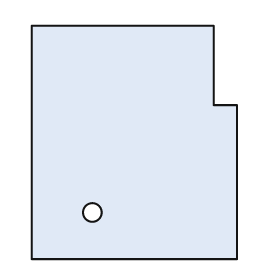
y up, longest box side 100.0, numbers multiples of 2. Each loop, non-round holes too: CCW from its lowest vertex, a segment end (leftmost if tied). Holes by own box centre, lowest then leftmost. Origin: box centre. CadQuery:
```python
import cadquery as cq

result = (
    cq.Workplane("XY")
    .moveTo(-44.0, -50.0)
    .lineTo(44.0, -50.0)
    .lineTo(44.0, 16.0)
    .lineTo(34.0, 16.0)
    .lineTo(34.0, 50.0)
    .lineTo(-44.0, 50.0)
    .close()
    .moveTo(-18.0, -30.0)
    .circle(4.0)
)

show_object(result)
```